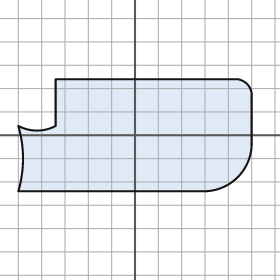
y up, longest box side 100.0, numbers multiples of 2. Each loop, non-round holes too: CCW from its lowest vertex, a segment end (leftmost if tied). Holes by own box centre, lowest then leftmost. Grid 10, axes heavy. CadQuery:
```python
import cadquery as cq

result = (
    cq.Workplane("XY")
    .moveTo(-50.0, -24.0)
    .lineTo(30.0, -24.0)
    .threePointArc((44.0, -18.0), (50.0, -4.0))
    .lineTo(50.0, 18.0)
    .threePointArc((48.0, 22.0), (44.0, 24.0))
    .lineTo(-34.0, 24.0)
    .lineTo(-34.0, 4.0)
    .threePointArc((-42.0, 2.0), (-50.0, 4.0))
    .threePointArc((-48.0, -10.0), (-50.0, -24.0))
    .close()
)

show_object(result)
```